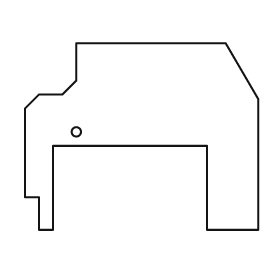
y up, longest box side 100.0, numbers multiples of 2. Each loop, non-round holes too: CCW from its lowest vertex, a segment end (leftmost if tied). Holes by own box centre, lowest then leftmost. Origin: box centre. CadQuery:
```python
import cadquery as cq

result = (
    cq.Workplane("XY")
    .moveTo(-44.0, -40.0)
    .lineTo(-38.0, -40.0)
    .lineTo(-38.0, -4.0)
    .lineTo(28.0, -4.0)
    .lineTo(28.0, -40.0)
    .lineTo(50.0, -40.0)
    .lineTo(50.0, 16.0)
    .lineTo(36.0, 40.0)
    .lineTo(-28.0, 40.0)
    .lineTo(-28.0, 24.0)
    .lineTo(-34.0, 18.0)
    .lineTo(-44.0, 18.0)
    .lineTo(-50.0, 12.0)
    .lineTo(-50.0, -26.0)
    .lineTo(-44.0, -26.0)
    .close()
    .moveTo(-28.0, 2.0)
    .circle(2.0)
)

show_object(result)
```